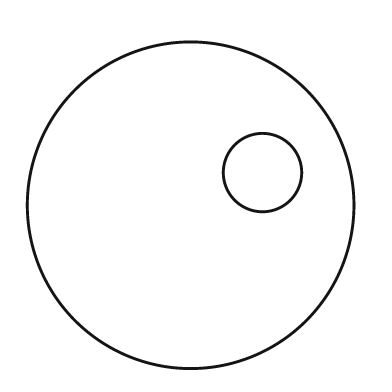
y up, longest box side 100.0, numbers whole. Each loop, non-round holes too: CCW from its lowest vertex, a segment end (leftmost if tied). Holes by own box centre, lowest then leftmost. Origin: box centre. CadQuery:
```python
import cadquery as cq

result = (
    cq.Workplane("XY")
    .moveTo(0.0, 0.0)
    .circle(50.0)
    .moveTo(22.0, 10.0)
    .circle(12.0)
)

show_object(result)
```